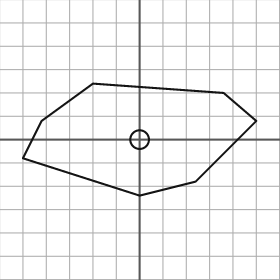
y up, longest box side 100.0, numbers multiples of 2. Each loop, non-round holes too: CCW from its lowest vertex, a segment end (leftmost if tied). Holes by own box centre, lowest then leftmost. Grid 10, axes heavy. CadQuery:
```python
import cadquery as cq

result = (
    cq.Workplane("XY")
    .moveTo(0.0, -24.0)
    .lineTo(24.0, -18.0)
    .lineTo(50.0, 8.0)
    .lineTo(36.0, 20.0)
    .lineTo(-20.0, 24.0)
    .lineTo(-42.0, 8.0)
    .lineTo(-50.0, -8.0)
    .close()
    .moveTo(0.0, 0.0)
    .circle(4.0)
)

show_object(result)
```